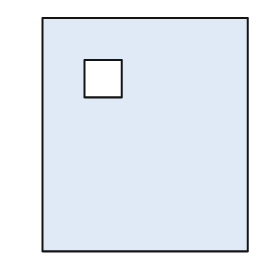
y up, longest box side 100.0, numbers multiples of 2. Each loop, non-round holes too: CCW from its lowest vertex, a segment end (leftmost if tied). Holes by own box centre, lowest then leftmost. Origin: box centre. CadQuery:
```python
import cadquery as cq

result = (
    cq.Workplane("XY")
    .moveTo(-44.0, -50.0)
    .lineTo(44.0, -50.0)
    .lineTo(44.0, 50.0)
    .lineTo(-44.0, 50.0)
    .close()
    .moveTo(-26.0, 16.0)
    .lineTo(-10.0, 16.0)
    .lineTo(-10.0, 32.0)
    .lineTo(-26.0, 32.0)
    .close()
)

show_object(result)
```